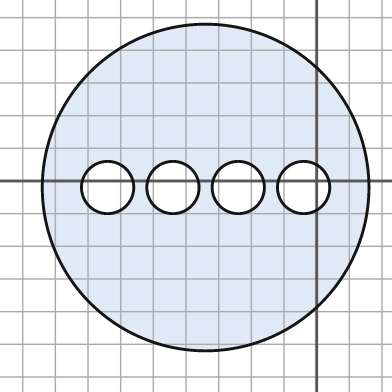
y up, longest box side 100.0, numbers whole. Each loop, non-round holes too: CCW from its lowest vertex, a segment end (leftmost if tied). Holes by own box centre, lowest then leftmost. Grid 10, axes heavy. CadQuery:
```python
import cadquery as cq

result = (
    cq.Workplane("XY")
    .moveTo(-34.0, -2.0)
    .circle(50.0)
    .moveTo(-64.0, -2.0)
    .circle(8.0)
    .moveTo(-44.0, -2.0)
    .circle(8.0)
    .moveTo(-24.0, -2.0)
    .circle(8.0)
    .moveTo(-4.0, -2.0)
    .circle(8.0)
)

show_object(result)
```